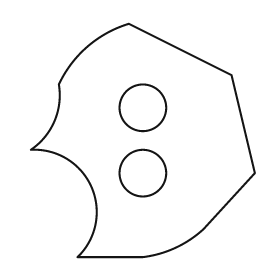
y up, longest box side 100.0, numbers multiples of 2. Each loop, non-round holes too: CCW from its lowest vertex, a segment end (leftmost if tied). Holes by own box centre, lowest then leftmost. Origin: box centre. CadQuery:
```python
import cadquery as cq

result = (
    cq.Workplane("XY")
    .moveTo(-28.0, -50.0)
    .lineTo(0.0, -50.0)
    .threePointArc((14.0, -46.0), (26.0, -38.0))
    .lineTo(48.0, -14.0)
    .lineTo(38.0, 28.0)
    .lineTo(-6.0, 50.0)
    .threePointArc((-24.0, 40.0), (-36.0, 24.0))
    .threePointArc((-38.0, 8.0), (-48.0, -4.0))
    .threePointArc((-22.0, -20.0), (-28.0, -50.0))
    .close()
    .moveTo(0.0, -14.0)
    .circle(10.0)
    .moveTo(0.0, 14.0)
    .circle(10.0)
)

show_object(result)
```